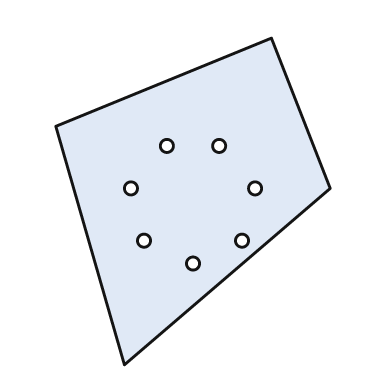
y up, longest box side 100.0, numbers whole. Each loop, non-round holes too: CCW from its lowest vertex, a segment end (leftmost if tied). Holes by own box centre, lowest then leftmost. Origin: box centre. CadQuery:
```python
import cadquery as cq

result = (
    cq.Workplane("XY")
    .moveTo(-21.0, -50.0)
    .lineTo(42.0, 4.0)
    .lineTo(24.0, 50.0)
    .lineTo(-42.0, 23.0)
    .close()
    .moveTo(0.0, -19.0)
    .circle(2.0)
    .moveTo(-15.0, -12.0)
    .circle(2.0)
    .moveTo(15.0, -12.0)
    .circle(2.0)
    .moveTo(-19.0, 4.0)
    .circle(2.0)
    .moveTo(19.0, 4.0)
    .circle(2.0)
    .moveTo(-8.0, 17.0)
    .circle(2.0)
    .moveTo(8.0, 17.0)
    .circle(2.0)
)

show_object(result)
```